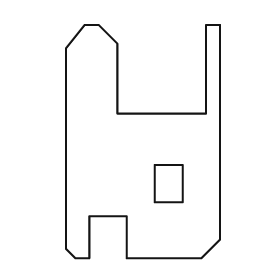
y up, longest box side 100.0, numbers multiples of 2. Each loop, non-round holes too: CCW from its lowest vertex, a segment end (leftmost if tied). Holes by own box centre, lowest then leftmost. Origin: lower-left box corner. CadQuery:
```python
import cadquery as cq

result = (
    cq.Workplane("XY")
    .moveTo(4.0, 0.0)
    .lineTo(10.0, 0.0)
    .lineTo(10.0, 18.0)
    .lineTo(26.0, 18.0)
    .lineTo(26.0, 0.0)
    .lineTo(58.0, 0.0)
    .lineTo(66.0, 8.0)
    .lineTo(66.0, 100.0)
    .lineTo(60.0, 100.0)
    .lineTo(60.0, 62.0)
    .lineTo(22.0, 62.0)
    .lineTo(22.0, 92.0)
    .lineTo(14.0, 100.0)
    .lineTo(8.0, 100.0)
    .lineTo(0.0, 90.0)
    .lineTo(0.0, 4.0)
    .close()
    .moveTo(38.0, 24.0)
    .lineTo(50.0, 24.0)
    .lineTo(50.0, 40.0)
    .lineTo(38.0, 40.0)
    .close()
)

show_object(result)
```